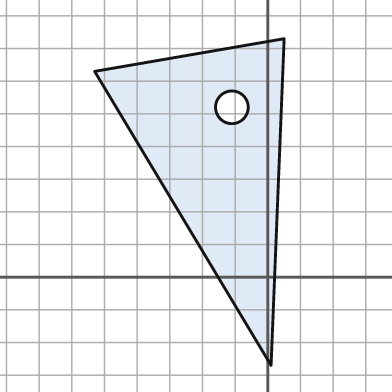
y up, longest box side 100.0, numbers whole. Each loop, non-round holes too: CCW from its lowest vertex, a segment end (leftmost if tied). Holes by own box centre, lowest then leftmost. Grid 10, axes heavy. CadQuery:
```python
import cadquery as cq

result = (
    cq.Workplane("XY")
    .moveTo(1.0, -27.0)
    .lineTo(5.0, 73.0)
    .lineTo(-53.0, 63.0)
    .close()
    .moveTo(-11.0, 52.0)
    .circle(5.0)
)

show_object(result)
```